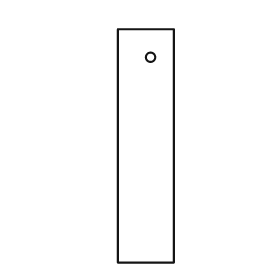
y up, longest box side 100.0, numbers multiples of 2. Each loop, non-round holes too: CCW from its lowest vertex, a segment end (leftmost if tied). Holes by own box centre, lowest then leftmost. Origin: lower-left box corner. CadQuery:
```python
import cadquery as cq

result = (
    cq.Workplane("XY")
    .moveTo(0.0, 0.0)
    .lineTo(24.0, 0.0)
    .lineTo(24.0, 100.0)
    .lineTo(0.0, 100.0)
    .close()
    .moveTo(14.0, 88.0)
    .circle(2.0)
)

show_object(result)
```